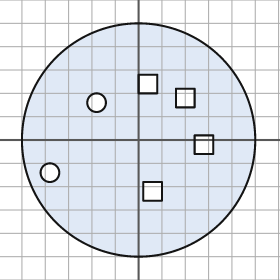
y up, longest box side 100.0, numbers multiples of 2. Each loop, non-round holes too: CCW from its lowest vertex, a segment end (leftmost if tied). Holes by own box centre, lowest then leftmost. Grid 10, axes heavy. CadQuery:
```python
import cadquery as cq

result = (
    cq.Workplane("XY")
    .moveTo(0.0, 0.0)
    .circle(50.0)
    .moveTo(2.0, -26.0)
    .lineTo(10.0, -26.0)
    .lineTo(10.0, -18.0)
    .lineTo(2.0, -18.0)
    .close()
    .moveTo(-38.0, -14.0)
    .circle(4.0)
    .moveTo(24.0, -6.0)
    .lineTo(32.0, -6.0)
    .lineTo(32.0, 2.0)
    .lineTo(24.0, 2.0)
    .close()
    .moveTo(-18.0, 16.0)
    .circle(4.0)
    .moveTo(16.0, 14.0)
    .lineTo(24.0, 14.0)
    .lineTo(24.0, 22.0)
    .lineTo(16.0, 22.0)
    .close()
    .moveTo(0.0, 20.0)
    .lineTo(8.0, 20.0)
    .lineTo(8.0, 28.0)
    .lineTo(0.0, 28.0)
    .close()
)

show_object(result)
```